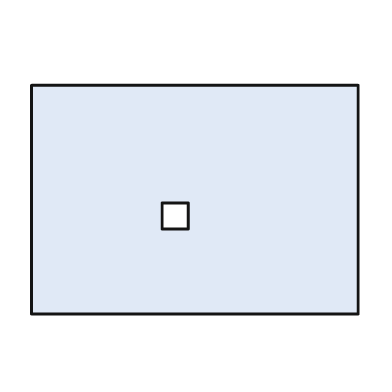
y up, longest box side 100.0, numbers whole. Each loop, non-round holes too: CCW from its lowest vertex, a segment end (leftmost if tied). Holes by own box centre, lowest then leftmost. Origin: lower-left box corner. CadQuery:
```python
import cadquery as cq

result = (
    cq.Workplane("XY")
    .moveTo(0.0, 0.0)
    .lineTo(100.0, 0.0)
    .lineTo(100.0, 70.0)
    .lineTo(0.0, 70.0)
    .close()
    .moveTo(40.0, 26.0)
    .lineTo(48.0, 26.0)
    .lineTo(48.0, 34.0)
    .lineTo(40.0, 34.0)
    .close()
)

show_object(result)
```